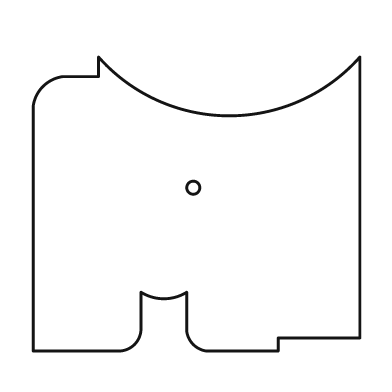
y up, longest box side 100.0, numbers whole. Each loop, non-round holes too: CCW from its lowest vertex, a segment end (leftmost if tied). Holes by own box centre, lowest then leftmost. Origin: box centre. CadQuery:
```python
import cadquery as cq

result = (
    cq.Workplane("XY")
    .moveTo(-50.0, -45.0)
    .lineTo(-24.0, -45.0)
    .threePointArc((-19.0, -43.0), (-17.0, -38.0))
    .lineTo(-17.0, -27.0)
    .threePointArc((-10.0, -29.0), (-3.0, -27.0))
    .lineTo(-3.0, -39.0)
    .threePointArc((-1.0, -43.0), (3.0, -45.0))
    .lineTo(25.0, -45.0)
    .lineTo(25.0, -41.0)
    .lineTo(50.0, -41.0)
    .lineTo(50.0, 45.0)
    .threePointArc((10.0, 27.0), (-30.0, 45.0))
    .lineTo(-30.0, 39.0)
    .lineTo(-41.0, 39.0)
    .threePointArc((-47.0, 36.0), (-50.0, 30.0))
    .close()
    .moveTo(-1.0, 5.0)
    .circle(2.0)
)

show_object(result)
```